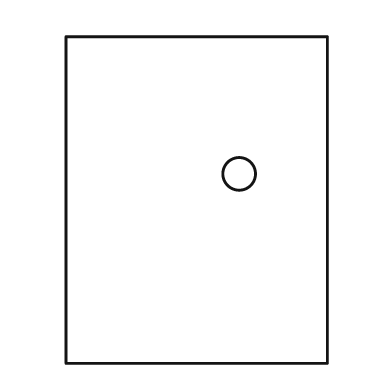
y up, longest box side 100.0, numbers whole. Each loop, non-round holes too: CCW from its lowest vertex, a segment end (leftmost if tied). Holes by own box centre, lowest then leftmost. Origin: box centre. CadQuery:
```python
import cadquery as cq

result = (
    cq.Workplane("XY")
    .moveTo(-40.0, -50.0)
    .lineTo(40.0, -50.0)
    .lineTo(40.0, 50.0)
    .lineTo(-40.0, 50.0)
    .close()
    .moveTo(13.0, 8.0)
    .circle(5.0)
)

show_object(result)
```